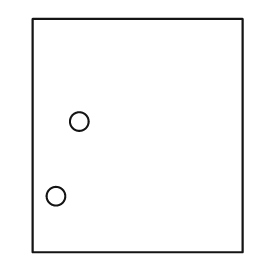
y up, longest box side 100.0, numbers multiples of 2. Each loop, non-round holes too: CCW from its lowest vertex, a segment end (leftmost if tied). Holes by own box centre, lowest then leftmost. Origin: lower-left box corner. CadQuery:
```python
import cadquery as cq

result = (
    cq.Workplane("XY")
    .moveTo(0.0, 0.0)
    .lineTo(90.0, 0.0)
    .lineTo(90.0, 100.0)
    .lineTo(0.0, 100.0)
    .close()
    .moveTo(10.0, 24.0)
    .circle(4.0)
    .moveTo(20.0, 56.0)
    .circle(4.0)
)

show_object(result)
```